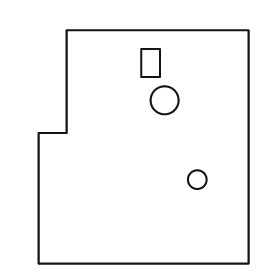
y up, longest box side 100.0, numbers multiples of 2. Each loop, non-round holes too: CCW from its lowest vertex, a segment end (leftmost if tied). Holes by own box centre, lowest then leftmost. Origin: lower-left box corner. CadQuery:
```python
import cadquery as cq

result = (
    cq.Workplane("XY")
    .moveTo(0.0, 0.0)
    .lineTo(90.0, 0.0)
    .lineTo(90.0, 100.0)
    .lineTo(12.0, 100.0)
    .lineTo(12.0, 56.0)
    .lineTo(0.0, 56.0)
    .close()
    .moveTo(68.0, 36.0)
    .circle(4.0)
    .moveTo(54.0, 70.0)
    .circle(6.0)
    .moveTo(44.0, 80.0)
    .lineTo(52.0, 80.0)
    .lineTo(52.0, 92.0)
    .lineTo(44.0, 92.0)
    .close()
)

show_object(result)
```